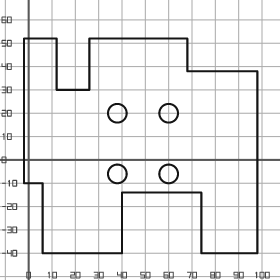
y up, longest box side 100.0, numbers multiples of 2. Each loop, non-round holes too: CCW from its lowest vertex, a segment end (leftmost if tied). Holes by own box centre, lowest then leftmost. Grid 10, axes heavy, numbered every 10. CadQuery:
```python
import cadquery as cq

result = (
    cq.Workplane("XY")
    .moveTo(6.0, -40.0)
    .lineTo(40.0, -40.0)
    .lineTo(40.0, -14.0)
    .lineTo(74.0, -14.0)
    .lineTo(74.0, -40.0)
    .lineTo(98.0, -40.0)
    .lineTo(98.0, 38.0)
    .lineTo(68.0, 38.0)
    .lineTo(68.0, 52.0)
    .lineTo(26.0, 52.0)
    .lineTo(26.0, 30.0)
    .lineTo(12.0, 30.0)
    .lineTo(12.0, 52.0)
    .lineTo(-2.0, 52.0)
    .lineTo(-2.0, -10.0)
    .lineTo(6.0, -10.0)
    .close()
    .moveTo(38.0, -6.0)
    .circle(4.0)
    .moveTo(60.0, -6.0)
    .circle(4.0)
    .moveTo(38.0, 20.0)
    .circle(4.0)
    .moveTo(60.0, 20.0)
    .circle(4.0)
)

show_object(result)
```